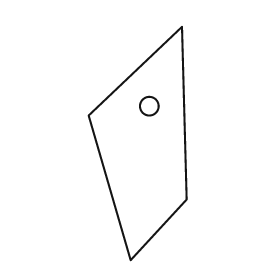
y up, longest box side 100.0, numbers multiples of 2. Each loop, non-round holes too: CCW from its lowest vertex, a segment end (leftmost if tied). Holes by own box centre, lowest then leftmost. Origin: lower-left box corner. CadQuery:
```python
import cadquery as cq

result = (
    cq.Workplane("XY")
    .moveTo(18.0, 0.0)
    .lineTo(42.0, 26.0)
    .lineTo(40.0, 100.0)
    .lineTo(0.0, 62.0)
    .close()
    .moveTo(26.0, 66.0)
    .circle(4.0)
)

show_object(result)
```